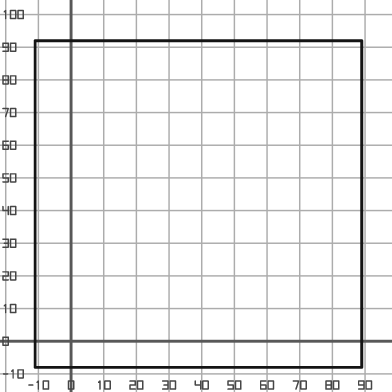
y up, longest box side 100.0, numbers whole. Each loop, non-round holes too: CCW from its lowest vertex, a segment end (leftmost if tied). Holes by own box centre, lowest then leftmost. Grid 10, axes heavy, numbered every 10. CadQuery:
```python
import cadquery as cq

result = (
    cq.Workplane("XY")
    .moveTo(-11.0, -8.0)
    .lineTo(89.0, -8.0)
    .lineTo(89.0, 92.0)
    .lineTo(-11.0, 92.0)
    .close()
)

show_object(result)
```